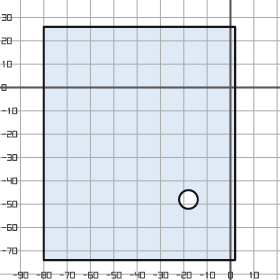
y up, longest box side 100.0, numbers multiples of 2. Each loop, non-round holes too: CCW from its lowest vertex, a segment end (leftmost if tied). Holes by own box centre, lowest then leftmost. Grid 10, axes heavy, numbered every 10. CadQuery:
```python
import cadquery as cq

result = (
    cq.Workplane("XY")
    .moveTo(-80.0, -74.0)
    .lineTo(2.0, -74.0)
    .lineTo(2.0, 26.0)
    .lineTo(-80.0, 26.0)
    .close()
    .moveTo(-18.0, -48.0)
    .circle(4.0)
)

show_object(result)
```